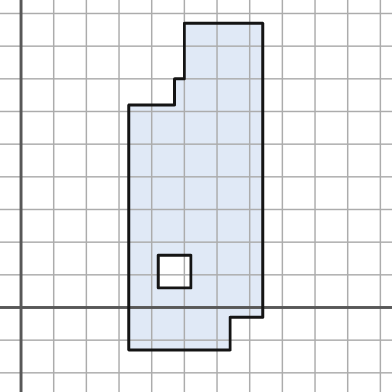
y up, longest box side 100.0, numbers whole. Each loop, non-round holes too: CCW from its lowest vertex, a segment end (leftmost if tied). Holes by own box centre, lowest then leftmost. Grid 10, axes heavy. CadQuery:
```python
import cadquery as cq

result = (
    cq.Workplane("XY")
    .moveTo(33.0, -13.0)
    .lineTo(64.0, -13.0)
    .lineTo(64.0, -3.0)
    .lineTo(74.0, -3.0)
    .lineTo(74.0, 87.0)
    .lineTo(50.0, 87.0)
    .lineTo(50.0, 70.0)
    .lineTo(47.0, 70.0)
    .lineTo(47.0, 62.0)
    .lineTo(33.0, 62.0)
    .close()
    .moveTo(42.0, 6.0)
    .lineTo(52.0, 6.0)
    .lineTo(52.0, 16.0)
    .lineTo(42.0, 16.0)
    .close()
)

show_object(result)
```